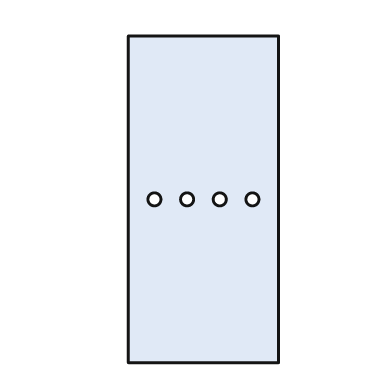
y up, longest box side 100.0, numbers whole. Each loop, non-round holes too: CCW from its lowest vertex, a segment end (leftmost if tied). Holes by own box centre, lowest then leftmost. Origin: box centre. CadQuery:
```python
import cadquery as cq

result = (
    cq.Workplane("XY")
    .moveTo(-23.0, -50.0)
    .lineTo(23.0, -50.0)
    .lineTo(23.0, 50.0)
    .lineTo(-23.0, 50.0)
    .close()
    .moveTo(-15.0, 0.0)
    .circle(2.0)
    .moveTo(-5.0, 0.0)
    .circle(2.0)
    .moveTo(5.0, 0.0)
    .circle(2.0)
    .moveTo(15.0, 0.0)
    .circle(2.0)
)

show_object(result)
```